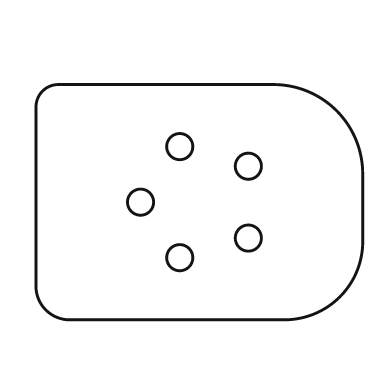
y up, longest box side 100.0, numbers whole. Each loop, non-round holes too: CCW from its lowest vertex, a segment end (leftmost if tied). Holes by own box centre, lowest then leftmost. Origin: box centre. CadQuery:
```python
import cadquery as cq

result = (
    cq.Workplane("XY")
    .moveTo(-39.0, -36.0)
    .lineTo(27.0, -36.0)
    .threePointArc((43.0, -29.0), (50.0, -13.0))
    .lineTo(50.0, 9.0)
    .threePointArc((42.0, 28.0), (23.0, 36.0))
    .lineTo(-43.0, 36.0)
    .threePointArc((-48.0, 34.0), (-50.0, 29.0))
    .lineTo(-50.0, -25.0)
    .threePointArc((-47.0, -33.0), (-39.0, -36.0))
    .close()
    .moveTo(-6.0, -17.0)
    .circle(4.0)
    .moveTo(15.0, -11.0)
    .circle(4.0)
    .moveTo(-18.0, 0.0)
    .circle(4.0)
    .moveTo(15.0, 11.0)
    .circle(4.0)
    .moveTo(-6.0, 17.0)
    .circle(4.0)
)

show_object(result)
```